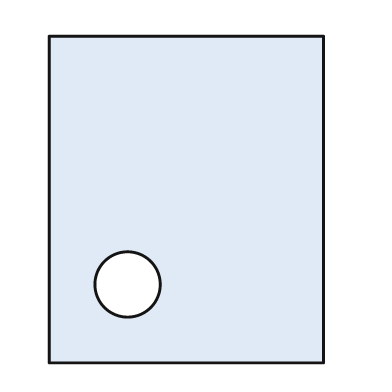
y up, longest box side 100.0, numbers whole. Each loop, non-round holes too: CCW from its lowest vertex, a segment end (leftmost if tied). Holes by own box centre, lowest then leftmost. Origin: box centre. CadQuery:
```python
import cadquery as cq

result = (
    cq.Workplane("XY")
    .moveTo(-42.0, -50.0)
    .lineTo(42.0, -50.0)
    .lineTo(42.0, 50.0)
    .lineTo(-42.0, 50.0)
    .close()
    .moveTo(-18.0, -26.0)
    .circle(10.0)
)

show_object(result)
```